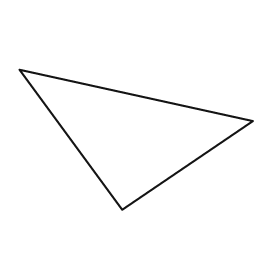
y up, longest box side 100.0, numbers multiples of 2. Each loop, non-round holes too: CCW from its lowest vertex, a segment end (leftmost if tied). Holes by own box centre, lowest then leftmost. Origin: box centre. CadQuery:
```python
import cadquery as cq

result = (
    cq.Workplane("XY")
    .moveTo(-6.0, -30.0)
    .lineTo(50.0, 8.0)
    .lineTo(-50.0, 30.0)
    .close()
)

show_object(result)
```